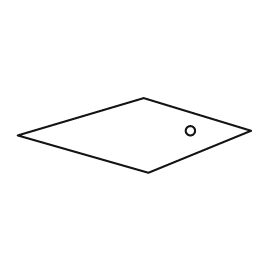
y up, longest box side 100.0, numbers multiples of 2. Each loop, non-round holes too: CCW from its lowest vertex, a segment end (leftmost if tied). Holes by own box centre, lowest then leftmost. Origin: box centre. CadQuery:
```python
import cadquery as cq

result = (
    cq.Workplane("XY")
    .moveTo(6.0, -16.0)
    .lineTo(50.0, 2.0)
    .lineTo(4.0, 16.0)
    .lineTo(-50.0, 0.0)
    .close()
    .moveTo(24.0, 2.0)
    .circle(2.0)
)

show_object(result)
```